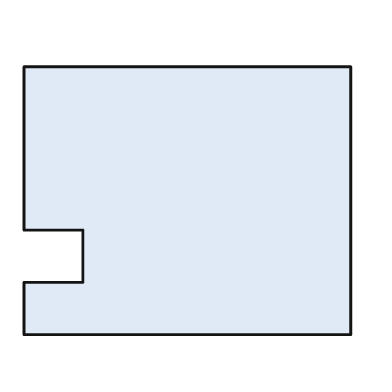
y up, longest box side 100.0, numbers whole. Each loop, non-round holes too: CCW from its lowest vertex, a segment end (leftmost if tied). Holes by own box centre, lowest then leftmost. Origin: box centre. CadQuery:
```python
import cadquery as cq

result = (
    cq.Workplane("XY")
    .moveTo(-50.0, -41.0)
    .lineTo(50.0, -41.0)
    .lineTo(50.0, 41.0)
    .lineTo(-50.0, 41.0)
    .lineTo(-50.0, -9.0)
    .lineTo(-32.0, -9.0)
    .lineTo(-32.0, -25.0)
    .lineTo(-50.0, -25.0)
    .close()
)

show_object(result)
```